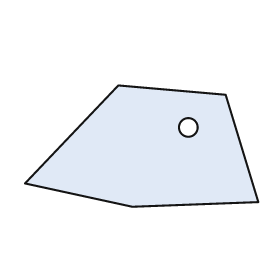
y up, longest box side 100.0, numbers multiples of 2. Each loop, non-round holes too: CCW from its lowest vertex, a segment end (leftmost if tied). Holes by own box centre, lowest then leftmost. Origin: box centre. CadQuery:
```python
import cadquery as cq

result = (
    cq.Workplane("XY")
    .moveTo(-4.0, -26.0)
    .lineTo(50.0, -24.0)
    .lineTo(36.0, 22.0)
    .lineTo(-10.0, 26.0)
    .lineTo(-50.0, -16.0)
    .close()
    .moveTo(20.0, 8.0)
    .circle(4.0)
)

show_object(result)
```